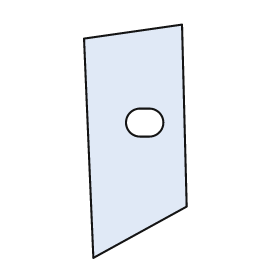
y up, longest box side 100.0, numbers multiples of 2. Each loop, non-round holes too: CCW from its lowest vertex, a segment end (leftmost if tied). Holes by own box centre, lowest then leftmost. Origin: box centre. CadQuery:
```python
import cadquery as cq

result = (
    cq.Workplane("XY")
    .moveTo(-18.0, -50.0)
    .lineTo(22.0, -28.0)
    .lineTo(20.0, 50.0)
    .lineTo(-22.0, 44.0)
    .close()
    .moveTo(2.0, 2.0)
    .lineTo(6.0, 2.0)
    .threePointArc((12.0, 8.0), (6.0, 14.0))
    .lineTo(2.0, 14.0)
    .threePointArc((-4.0, 8.0), (2.0, 2.0))
    .close()
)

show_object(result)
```